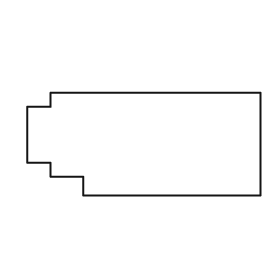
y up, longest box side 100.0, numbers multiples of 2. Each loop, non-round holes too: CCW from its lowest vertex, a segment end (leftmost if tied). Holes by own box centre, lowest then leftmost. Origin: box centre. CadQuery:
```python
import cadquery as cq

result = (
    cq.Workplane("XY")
    .moveTo(-26.0, -22.0)
    .lineTo(50.0, -22.0)
    .lineTo(50.0, 22.0)
    .lineTo(-40.0, 22.0)
    .lineTo(-40.0, 16.0)
    .lineTo(-50.0, 16.0)
    .lineTo(-50.0, -8.0)
    .lineTo(-40.0, -8.0)
    .lineTo(-40.0, -14.0)
    .lineTo(-26.0, -14.0)
    .close()
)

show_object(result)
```